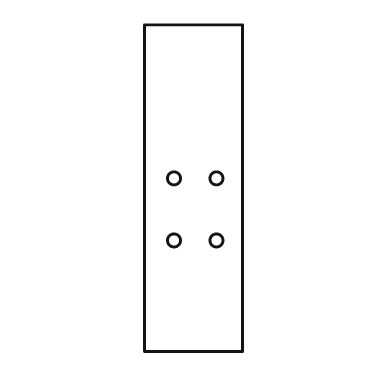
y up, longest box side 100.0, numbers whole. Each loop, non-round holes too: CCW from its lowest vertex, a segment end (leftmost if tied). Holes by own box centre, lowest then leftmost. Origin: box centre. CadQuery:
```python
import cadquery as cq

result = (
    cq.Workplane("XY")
    .moveTo(-15.0, -50.0)
    .lineTo(15.0, -50.0)
    .lineTo(15.0, 50.0)
    .lineTo(-15.0, 50.0)
    .close()
    .moveTo(-6.0, -16.0)
    .circle(2.0)
    .moveTo(7.0, -16.0)
    .circle(2.0)
    .moveTo(-6.0, 3.0)
    .circle(2.0)
    .moveTo(7.0, 3.0)
    .circle(2.0)
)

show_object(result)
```